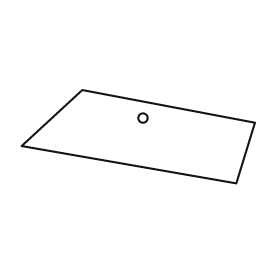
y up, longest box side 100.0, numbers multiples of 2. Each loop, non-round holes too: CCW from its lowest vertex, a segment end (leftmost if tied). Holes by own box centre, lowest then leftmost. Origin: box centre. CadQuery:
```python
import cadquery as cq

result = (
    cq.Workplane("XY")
    .moveTo(42.0, -20.0)
    .lineTo(50.0, 6.0)
    .lineTo(-24.0, 20.0)
    .lineTo(-50.0, -4.0)
    .close()
    .moveTo(2.0, 8.0)
    .circle(2.0)
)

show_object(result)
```